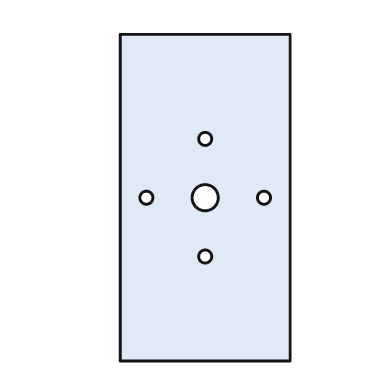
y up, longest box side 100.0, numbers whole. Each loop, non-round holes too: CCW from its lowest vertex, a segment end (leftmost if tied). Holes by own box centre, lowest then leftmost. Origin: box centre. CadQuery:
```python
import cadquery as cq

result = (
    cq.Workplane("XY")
    .moveTo(-26.0, -50.0)
    .lineTo(26.0, -50.0)
    .lineTo(26.0, 50.0)
    .lineTo(-26.0, 50.0)
    .close()
    .moveTo(0.0, -18.0)
    .circle(2.0)
    .moveTo(-18.0, 0.0)
    .circle(2.0)
    .moveTo(0.0, 0.0)
    .circle(4.0)
    .moveTo(18.0, 0.0)
    .circle(2.0)
    .moveTo(0.0, 18.0)
    .circle(2.0)
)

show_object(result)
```